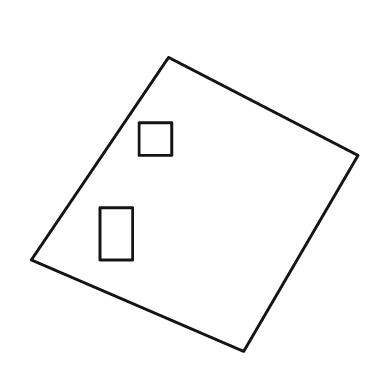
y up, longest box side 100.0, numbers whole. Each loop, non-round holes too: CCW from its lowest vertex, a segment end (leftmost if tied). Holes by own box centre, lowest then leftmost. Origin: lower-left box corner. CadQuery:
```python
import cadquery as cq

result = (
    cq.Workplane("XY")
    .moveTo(65.0, 0.0)
    .lineTo(100.0, 60.0)
    .lineTo(42.0, 90.0)
    .lineTo(0.0, 28.0)
    .close()
    .moveTo(21.0, 28.0)
    .lineTo(31.0, 28.0)
    .lineTo(31.0, 44.0)
    .lineTo(21.0, 44.0)
    .close()
    .moveTo(33.0, 60.0)
    .lineTo(43.0, 60.0)
    .lineTo(43.0, 70.0)
    .lineTo(33.0, 70.0)
    .close()
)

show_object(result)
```